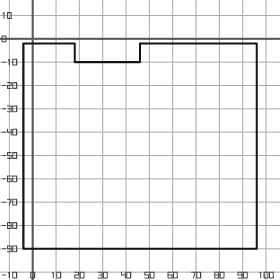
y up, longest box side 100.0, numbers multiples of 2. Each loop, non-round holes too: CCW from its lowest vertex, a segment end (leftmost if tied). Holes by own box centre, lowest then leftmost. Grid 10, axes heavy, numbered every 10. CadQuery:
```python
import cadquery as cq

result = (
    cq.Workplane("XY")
    .moveTo(-4.0, -90.0)
    .lineTo(96.0, -90.0)
    .lineTo(96.0, -2.0)
    .lineTo(46.0, -2.0)
    .lineTo(46.0, -10.0)
    .lineTo(18.0, -10.0)
    .lineTo(18.0, -2.0)
    .lineTo(-4.0, -2.0)
    .close()
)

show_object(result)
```